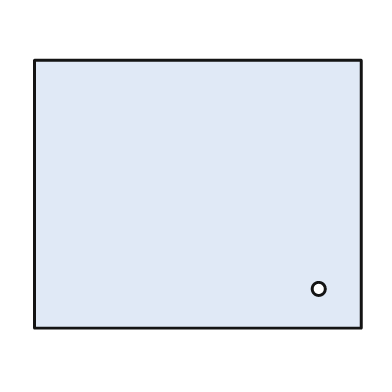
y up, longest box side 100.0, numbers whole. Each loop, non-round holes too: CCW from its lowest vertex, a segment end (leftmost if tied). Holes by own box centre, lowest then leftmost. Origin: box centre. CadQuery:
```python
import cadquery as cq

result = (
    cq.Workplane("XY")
    .moveTo(-50.0, -41.0)
    .lineTo(50.0, -41.0)
    .lineTo(50.0, 41.0)
    .lineTo(-50.0, 41.0)
    .close()
    .moveTo(37.0, -29.0)
    .circle(2.0)
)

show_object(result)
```